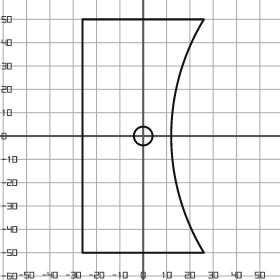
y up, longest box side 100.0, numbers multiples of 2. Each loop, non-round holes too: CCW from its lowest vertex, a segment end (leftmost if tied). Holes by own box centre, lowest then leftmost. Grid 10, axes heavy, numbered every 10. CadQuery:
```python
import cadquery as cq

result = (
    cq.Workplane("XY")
    .moveTo(-26.0, -50.0)
    .lineTo(26.0, -50.0)
    .threePointArc((12.0, 0.0), (26.0, 50.0))
    .lineTo(-26.0, 50.0)
    .close()
    .moveTo(0.0, 0.0)
    .circle(4.0)
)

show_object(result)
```